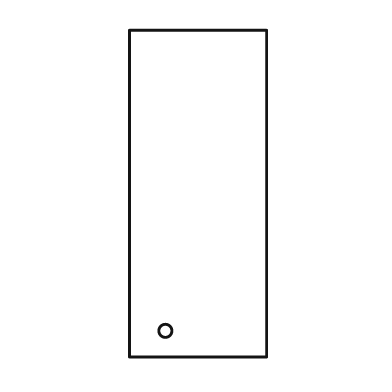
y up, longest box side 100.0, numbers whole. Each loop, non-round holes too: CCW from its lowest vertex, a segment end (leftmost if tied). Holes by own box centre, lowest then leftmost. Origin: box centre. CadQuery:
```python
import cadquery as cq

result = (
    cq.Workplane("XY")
    .moveTo(-21.0, -50.0)
    .lineTo(21.0, -50.0)
    .lineTo(21.0, 50.0)
    .lineTo(-21.0, 50.0)
    .close()
    .moveTo(-10.0, -42.0)
    .circle(2.0)
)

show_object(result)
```